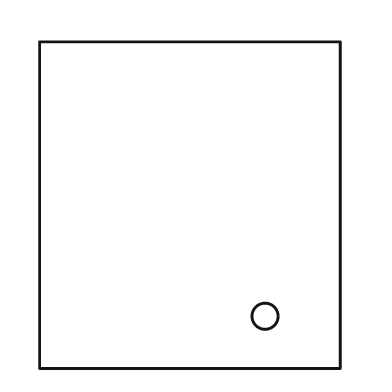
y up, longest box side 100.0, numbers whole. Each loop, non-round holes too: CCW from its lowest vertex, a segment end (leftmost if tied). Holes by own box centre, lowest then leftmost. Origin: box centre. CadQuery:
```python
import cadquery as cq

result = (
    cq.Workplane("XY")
    .moveTo(-46.0, -50.0)
    .lineTo(46.0, -50.0)
    .lineTo(46.0, 50.0)
    .lineTo(-46.0, 50.0)
    .close()
    .moveTo(23.0, -34.0)
    .circle(4.0)
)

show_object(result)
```